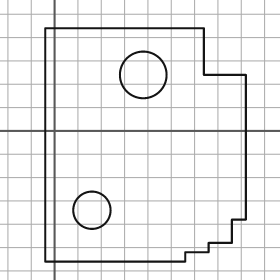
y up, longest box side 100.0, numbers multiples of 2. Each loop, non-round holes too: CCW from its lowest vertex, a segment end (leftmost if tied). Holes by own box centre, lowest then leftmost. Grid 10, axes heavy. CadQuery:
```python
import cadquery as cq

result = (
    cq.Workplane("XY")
    .moveTo(-4.0, -56.0)
    .lineTo(56.0, -56.0)
    .lineTo(56.0, -52.0)
    .lineTo(66.0, -52.0)
    .lineTo(66.0, -48.0)
    .lineTo(76.0, -48.0)
    .lineTo(76.0, -38.0)
    .lineTo(82.0, -38.0)
    .lineTo(82.0, 24.0)
    .lineTo(64.0, 24.0)
    .lineTo(64.0, 44.0)
    .lineTo(-4.0, 44.0)
    .close()
    .moveTo(16.0, -34.0)
    .circle(8.0)
    .moveTo(38.0, 24.0)
    .circle(10.0)
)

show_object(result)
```